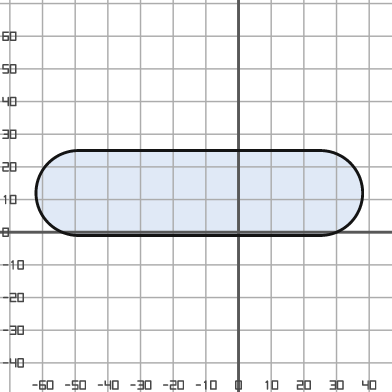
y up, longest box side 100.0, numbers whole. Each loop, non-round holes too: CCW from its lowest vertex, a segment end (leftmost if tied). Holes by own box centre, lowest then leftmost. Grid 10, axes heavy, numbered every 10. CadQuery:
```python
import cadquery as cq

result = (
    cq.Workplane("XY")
    .moveTo(-49.0, -1.0)
    .lineTo(25.0, -1.0)
    .threePointArc((38.0, 12.0), (25.0, 25.0))
    .lineTo(-49.0, 25.0)
    .threePointArc((-62.0, 12.0), (-49.0, -1.0))
    .close()
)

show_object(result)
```